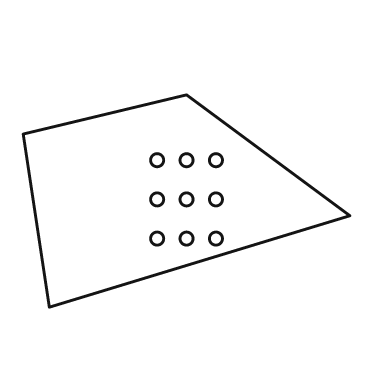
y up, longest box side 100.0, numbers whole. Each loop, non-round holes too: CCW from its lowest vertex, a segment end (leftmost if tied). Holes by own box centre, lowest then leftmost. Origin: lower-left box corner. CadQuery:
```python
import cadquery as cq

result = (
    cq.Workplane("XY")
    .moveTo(8.0, 0.0)
    .lineTo(100.0, 28.0)
    .lineTo(50.0, 65.0)
    .lineTo(0.0, 53.0)
    .close()
    .moveTo(41.0, 21.0)
    .circle(2.0)
    .moveTo(50.0, 21.0)
    .circle(2.0)
    .moveTo(59.0, 21.0)
    .circle(2.0)
    .moveTo(41.0, 33.0)
    .circle(2.0)
    .moveTo(50.0, 33.0)
    .circle(2.0)
    .moveTo(59.0, 33.0)
    .circle(2.0)
    .moveTo(41.0, 45.0)
    .circle(2.0)
    .moveTo(50.0, 45.0)
    .circle(2.0)
    .moveTo(59.0, 45.0)
    .circle(2.0)
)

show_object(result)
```